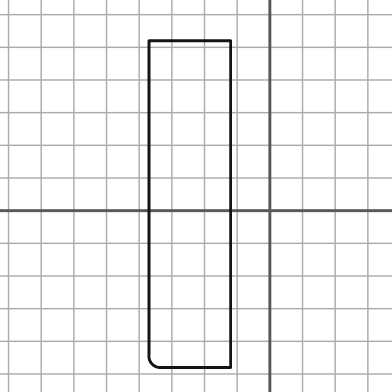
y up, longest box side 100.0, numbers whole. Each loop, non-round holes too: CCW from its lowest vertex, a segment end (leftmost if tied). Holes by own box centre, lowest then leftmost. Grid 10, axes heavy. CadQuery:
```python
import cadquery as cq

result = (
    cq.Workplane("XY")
    .moveTo(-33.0, -48.0)
    .lineTo(-12.0, -48.0)
    .lineTo(-12.0, 52.0)
    .lineTo(-37.0, 52.0)
    .lineTo(-37.0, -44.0)
    .threePointArc((-36.0, -47.0), (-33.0, -48.0))
    .close()
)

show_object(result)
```